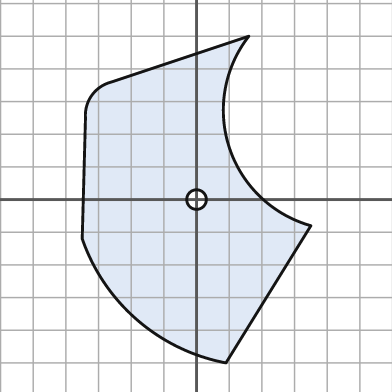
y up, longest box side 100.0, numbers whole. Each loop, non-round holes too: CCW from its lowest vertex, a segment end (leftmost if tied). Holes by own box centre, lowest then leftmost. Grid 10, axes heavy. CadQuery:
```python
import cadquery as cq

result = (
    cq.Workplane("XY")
    .moveTo(9.0, -50.0)
    .lineTo(35.0, -8.0)
    .threePointArc((10.0, 16.0), (16.0, 50.0))
    .lineTo(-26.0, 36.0)
    .threePointArc((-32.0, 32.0), (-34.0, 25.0))
    .lineTo(-35.0, -12.0)
    .threePointArc((-18.0, -37.0), (9.0, -50.0))
    .close()
    .moveTo(0.0, 0.0)
    .circle(3.0)
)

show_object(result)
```